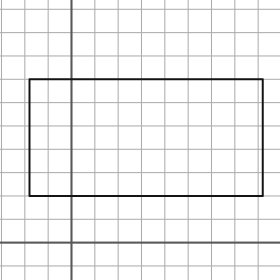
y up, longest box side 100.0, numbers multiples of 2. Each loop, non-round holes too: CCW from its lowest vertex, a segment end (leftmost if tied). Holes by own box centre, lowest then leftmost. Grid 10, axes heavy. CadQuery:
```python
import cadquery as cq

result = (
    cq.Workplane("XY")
    .moveTo(-18.0, 20.0)
    .lineTo(82.0, 20.0)
    .lineTo(82.0, 70.0)
    .lineTo(-18.0, 70.0)
    .close()
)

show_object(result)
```